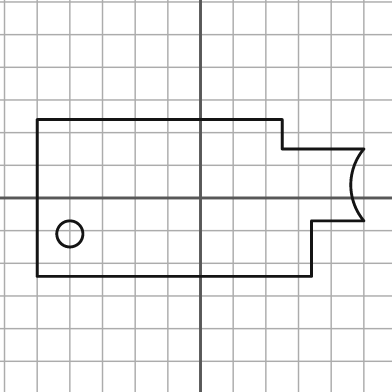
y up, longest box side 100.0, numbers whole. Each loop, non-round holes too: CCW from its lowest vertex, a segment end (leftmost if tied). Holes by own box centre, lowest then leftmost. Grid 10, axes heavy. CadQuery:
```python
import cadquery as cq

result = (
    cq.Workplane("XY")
    .moveTo(-50.0, -24.0)
    .lineTo(34.0, -24.0)
    .lineTo(34.0, -7.0)
    .lineTo(50.0, -7.0)
    .threePointArc((46.0, 4.0), (50.0, 15.0))
    .lineTo(25.0, 15.0)
    .lineTo(25.0, 24.0)
    .lineTo(-50.0, 24.0)
    .close()
    .moveTo(-40.0, -11.0)
    .circle(4.0)
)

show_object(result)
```